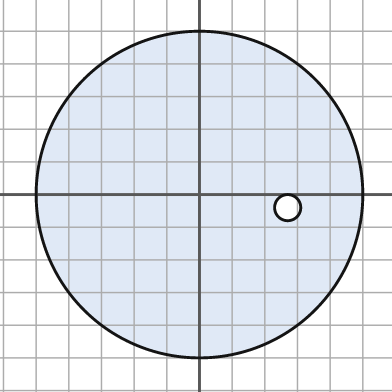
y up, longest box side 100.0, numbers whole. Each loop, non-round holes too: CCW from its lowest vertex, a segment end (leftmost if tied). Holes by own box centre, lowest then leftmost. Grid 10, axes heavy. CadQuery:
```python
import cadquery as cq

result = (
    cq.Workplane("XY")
    .moveTo(0.0, 0.0)
    .circle(50.0)
    .moveTo(27.0, -4.0)
    .circle(4.0)
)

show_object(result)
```